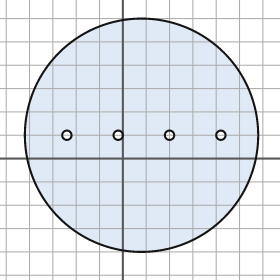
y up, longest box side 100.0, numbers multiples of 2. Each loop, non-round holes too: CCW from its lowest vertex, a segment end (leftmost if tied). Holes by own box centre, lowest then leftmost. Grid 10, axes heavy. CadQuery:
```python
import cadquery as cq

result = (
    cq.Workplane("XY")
    .moveTo(8.0, 10.0)
    .circle(50.0)
    .moveTo(-24.0, 10.0)
    .circle(2.0)
    .moveTo(-2.0, 10.0)
    .circle(2.0)
    .moveTo(20.0, 10.0)
    .circle(2.0)
    .moveTo(42.0, 10.0)
    .circle(2.0)
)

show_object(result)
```